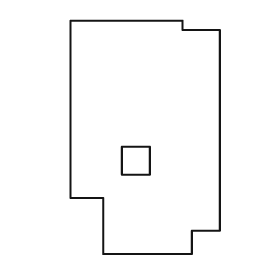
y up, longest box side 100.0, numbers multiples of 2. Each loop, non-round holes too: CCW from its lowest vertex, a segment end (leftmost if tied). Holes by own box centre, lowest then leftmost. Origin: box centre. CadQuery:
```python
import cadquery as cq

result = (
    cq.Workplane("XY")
    .moveTo(-18.0, -50.0)
    .lineTo(20.0, -50.0)
    .lineTo(20.0, -40.0)
    .lineTo(32.0, -40.0)
    .lineTo(32.0, 46.0)
    .lineTo(16.0, 46.0)
    .lineTo(16.0, 50.0)
    .lineTo(-32.0, 50.0)
    .lineTo(-32.0, -26.0)
    .lineTo(-18.0, -26.0)
    .close()
    .moveTo(-10.0, -16.0)
    .lineTo(2.0, -16.0)
    .lineTo(2.0, -4.0)
    .lineTo(-10.0, -4.0)
    .close()
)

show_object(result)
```